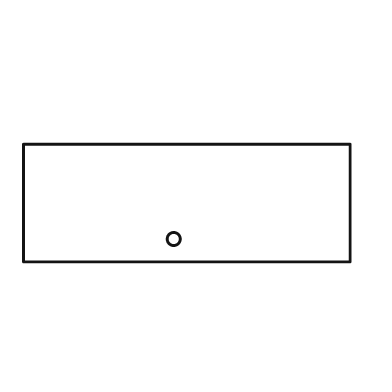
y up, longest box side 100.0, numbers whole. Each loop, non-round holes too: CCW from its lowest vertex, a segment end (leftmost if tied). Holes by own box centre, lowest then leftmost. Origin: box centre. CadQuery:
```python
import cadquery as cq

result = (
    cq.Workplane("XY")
    .moveTo(-50.0, -18.0)
    .lineTo(50.0, -18.0)
    .lineTo(50.0, 18.0)
    .lineTo(-50.0, 18.0)
    .close()
    .moveTo(-4.0, -11.0)
    .circle(2.0)
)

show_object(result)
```